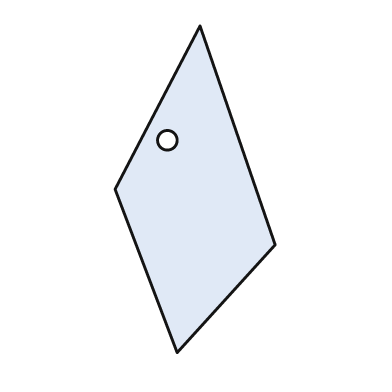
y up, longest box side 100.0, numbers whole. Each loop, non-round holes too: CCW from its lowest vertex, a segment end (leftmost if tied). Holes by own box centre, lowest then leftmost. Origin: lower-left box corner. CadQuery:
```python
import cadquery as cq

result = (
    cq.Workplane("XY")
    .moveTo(19.0, 0.0)
    .lineTo(49.0, 33.0)
    .lineTo(26.0, 100.0)
    .lineTo(0.0, 50.0)
    .close()
    .moveTo(16.0, 65.0)
    .circle(3.0)
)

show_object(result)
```